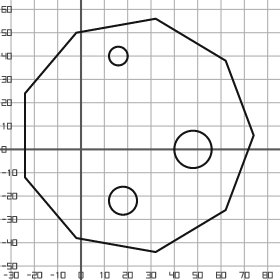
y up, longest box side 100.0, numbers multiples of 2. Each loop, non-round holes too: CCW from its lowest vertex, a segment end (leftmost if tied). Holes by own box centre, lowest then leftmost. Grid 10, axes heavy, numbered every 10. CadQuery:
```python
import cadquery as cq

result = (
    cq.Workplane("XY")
    .moveTo(32.0, -44.0)
    .lineTo(62.0, -26.0)
    .lineTo(74.0, 6.0)
    .lineTo(62.0, 38.0)
    .lineTo(32.0, 56.0)
    .lineTo(-2.0, 50.0)
    .lineTo(-24.0, 24.0)
    .lineTo(-24.0, -12.0)
    .lineTo(-2.0, -38.0)
    .close()
    .moveTo(18.0, -22.0)
    .circle(6.0)
    .moveTo(48.0, 0.0)
    .circle(8.0)
    .moveTo(16.0, 40.0)
    .circle(4.0)
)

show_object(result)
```